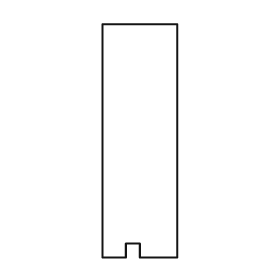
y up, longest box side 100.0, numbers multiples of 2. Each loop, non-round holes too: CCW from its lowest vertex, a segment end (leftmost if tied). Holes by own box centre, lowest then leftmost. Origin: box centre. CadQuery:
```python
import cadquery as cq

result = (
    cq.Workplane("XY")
    .moveTo(-16.0, -50.0)
    .lineTo(-6.0, -50.0)
    .lineTo(-6.0, -44.0)
    .lineTo(0.0, -44.0)
    .lineTo(0.0, -50.0)
    .lineTo(16.0, -50.0)
    .lineTo(16.0, 50.0)
    .lineTo(-16.0, 50.0)
    .close()
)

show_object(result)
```